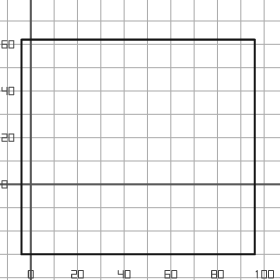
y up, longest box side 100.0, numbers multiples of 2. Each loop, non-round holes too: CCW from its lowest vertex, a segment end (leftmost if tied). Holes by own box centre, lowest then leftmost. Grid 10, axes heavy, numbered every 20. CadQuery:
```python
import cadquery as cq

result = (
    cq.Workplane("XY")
    .moveTo(-4.0, -30.0)
    .lineTo(96.0, -30.0)
    .lineTo(96.0, 62.0)
    .lineTo(-4.0, 62.0)
    .close()
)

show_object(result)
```